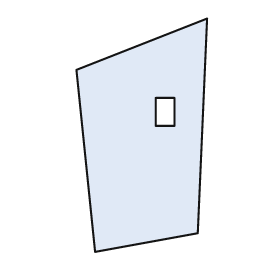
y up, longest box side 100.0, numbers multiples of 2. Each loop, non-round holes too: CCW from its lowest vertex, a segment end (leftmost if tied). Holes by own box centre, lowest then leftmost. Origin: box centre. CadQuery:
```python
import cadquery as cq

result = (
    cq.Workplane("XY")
    .moveTo(-20.0, -50.0)
    .lineTo(24.0, -42.0)
    .lineTo(28.0, 50.0)
    .lineTo(-28.0, 28.0)
    .close()
    .moveTo(6.0, 4.0)
    .lineTo(14.0, 4.0)
    .lineTo(14.0, 16.0)
    .lineTo(6.0, 16.0)
    .close()
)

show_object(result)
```